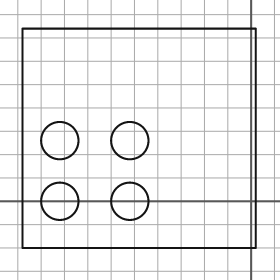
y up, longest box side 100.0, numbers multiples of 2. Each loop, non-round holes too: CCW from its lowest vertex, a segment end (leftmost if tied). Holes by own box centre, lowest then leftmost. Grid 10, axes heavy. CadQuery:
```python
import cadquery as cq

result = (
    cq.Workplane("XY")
    .moveTo(-98.0, -20.0)
    .lineTo(2.0, -20.0)
    .lineTo(2.0, 74.0)
    .lineTo(-98.0, 74.0)
    .close()
    .moveTo(-82.0, 0.0)
    .circle(8.0)
    .moveTo(-52.0, 0.0)
    .circle(8.0)
    .moveTo(-82.0, 26.0)
    .circle(8.0)
    .moveTo(-52.0, 26.0)
    .circle(8.0)
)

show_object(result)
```